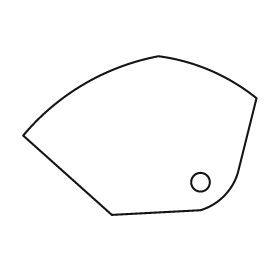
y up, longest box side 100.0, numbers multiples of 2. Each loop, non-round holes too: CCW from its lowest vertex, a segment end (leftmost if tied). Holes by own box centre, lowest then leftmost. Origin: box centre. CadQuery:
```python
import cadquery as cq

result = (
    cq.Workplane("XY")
    .moveTo(-12.0, -34.0)
    .lineTo(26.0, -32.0)
    .threePointArc((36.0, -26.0), (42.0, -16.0))
    .lineTo(50.0, 16.0)
    .threePointArc((30.0, 28.0), (8.0, 34.0))
    .threePointArc((-24.0, 22.0), (-50.0, 0.0))
    .close()
    .moveTo(26.0, -20.0)
    .circle(4.0)
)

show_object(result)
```